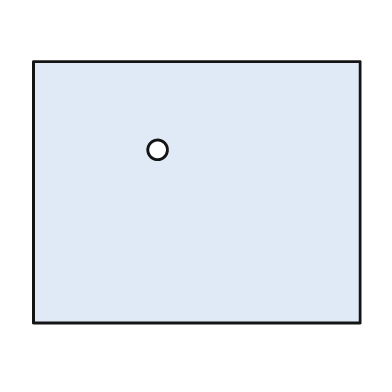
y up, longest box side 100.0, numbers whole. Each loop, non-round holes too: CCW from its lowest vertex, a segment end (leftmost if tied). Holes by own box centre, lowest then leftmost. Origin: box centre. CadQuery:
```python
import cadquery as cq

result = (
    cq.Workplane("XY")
    .moveTo(-50.0, -40.0)
    .lineTo(50.0, -40.0)
    .lineTo(50.0, 40.0)
    .lineTo(-50.0, 40.0)
    .close()
    .moveTo(-12.0, 13.0)
    .circle(3.0)
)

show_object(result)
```